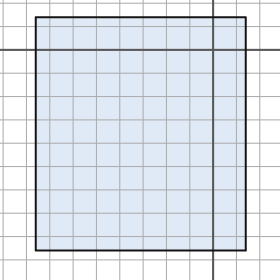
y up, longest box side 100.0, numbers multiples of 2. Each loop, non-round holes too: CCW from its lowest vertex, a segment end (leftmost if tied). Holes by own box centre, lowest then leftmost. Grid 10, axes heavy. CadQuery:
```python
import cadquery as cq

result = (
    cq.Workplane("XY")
    .moveTo(-76.0, -86.0)
    .lineTo(14.0, -86.0)
    .lineTo(14.0, 14.0)
    .lineTo(-76.0, 14.0)
    .close()
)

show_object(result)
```